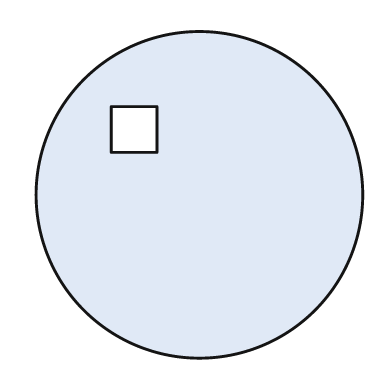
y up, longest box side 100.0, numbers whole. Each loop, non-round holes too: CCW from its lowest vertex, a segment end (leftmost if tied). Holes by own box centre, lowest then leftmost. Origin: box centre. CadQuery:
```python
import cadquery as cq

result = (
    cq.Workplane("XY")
    .moveTo(0.0, 0.0)
    .circle(50.0)
    .moveTo(-27.0, 13.0)
    .lineTo(-13.0, 13.0)
    .lineTo(-13.0, 27.0)
    .lineTo(-27.0, 27.0)
    .close()
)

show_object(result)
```